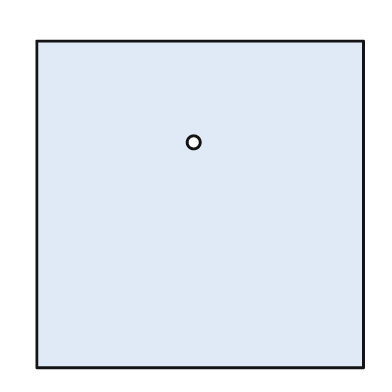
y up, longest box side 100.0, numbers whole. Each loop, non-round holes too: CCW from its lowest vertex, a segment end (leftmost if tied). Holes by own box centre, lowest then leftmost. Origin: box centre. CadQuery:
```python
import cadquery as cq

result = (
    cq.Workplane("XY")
    .moveTo(-50.0, -50.0)
    .lineTo(50.0, -50.0)
    .lineTo(50.0, 50.0)
    .lineTo(-50.0, 50.0)
    .close()
    .moveTo(-2.0, 19.0)
    .circle(2.0)
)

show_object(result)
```